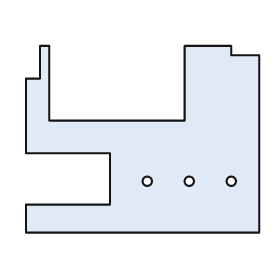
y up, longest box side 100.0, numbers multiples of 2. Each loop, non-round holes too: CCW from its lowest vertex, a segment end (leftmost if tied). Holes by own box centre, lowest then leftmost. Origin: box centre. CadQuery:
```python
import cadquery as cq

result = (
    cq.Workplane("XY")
    .moveTo(-50.0, -40.0)
    .lineTo(50.0, -40.0)
    .lineTo(50.0, 36.0)
    .lineTo(38.0, 36.0)
    .lineTo(38.0, 40.0)
    .lineTo(18.0, 40.0)
    .lineTo(18.0, 8.0)
    .lineTo(-40.0, 8.0)
    .lineTo(-40.0, 40.0)
    .lineTo(-44.0, 40.0)
    .lineTo(-44.0, 26.0)
    .lineTo(-50.0, 26.0)
    .lineTo(-50.0, -6.0)
    .lineTo(-14.0, -6.0)
    .lineTo(-14.0, -28.0)
    .lineTo(-50.0, -28.0)
    .close()
    .moveTo(2.0, -18.0)
    .circle(2.0)
    .moveTo(20.0, -18.0)
    .circle(2.0)
    .moveTo(38.0, -18.0)
    .circle(2.0)
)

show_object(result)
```